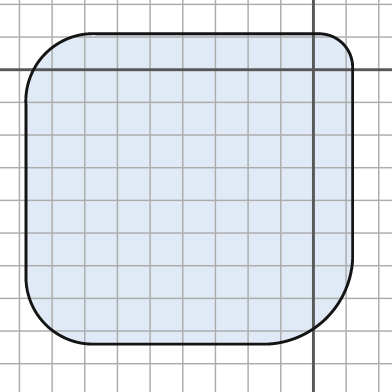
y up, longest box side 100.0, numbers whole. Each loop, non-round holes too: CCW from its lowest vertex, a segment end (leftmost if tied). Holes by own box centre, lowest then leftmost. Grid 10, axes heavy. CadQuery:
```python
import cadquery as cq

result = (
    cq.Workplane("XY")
    .moveTo(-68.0, -84.0)
    .lineTo(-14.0, -84.0)
    .threePointArc((4.0, -76.0), (12.0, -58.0))
    .lineTo(12.0, 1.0)
    .threePointArc((9.0, 8.0), (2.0, 11.0))
    .lineTo(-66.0, 11.0)
    .threePointArc((-82.0, 5.0), (-88.0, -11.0))
    .lineTo(-88.0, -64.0)
    .threePointArc((-82.0, -78.0), (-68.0, -84.0))
    .close()
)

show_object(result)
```